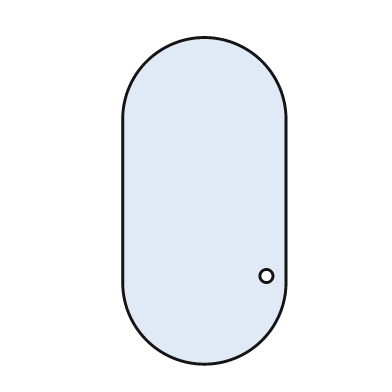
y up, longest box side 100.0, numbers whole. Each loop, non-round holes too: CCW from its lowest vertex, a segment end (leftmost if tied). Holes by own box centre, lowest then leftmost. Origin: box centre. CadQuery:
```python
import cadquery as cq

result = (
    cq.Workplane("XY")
    .moveTo(-25.0, -25.0)
    .threePointArc((0.0, -50.0), (25.0, -25.0))
    .lineTo(25.0, 25.0)
    .threePointArc((0.0, 50.0), (-25.0, 25.0))
    .close()
    .moveTo(19.0, -23.0)
    .circle(2.0)
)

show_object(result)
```